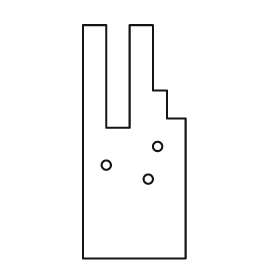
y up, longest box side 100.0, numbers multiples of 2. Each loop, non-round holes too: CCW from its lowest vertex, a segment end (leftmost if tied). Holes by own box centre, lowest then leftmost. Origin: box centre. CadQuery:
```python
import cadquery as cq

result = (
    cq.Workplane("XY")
    .moveTo(-22.0, -50.0)
    .lineTo(22.0, -50.0)
    .lineTo(22.0, 10.0)
    .lineTo(14.0, 10.0)
    .lineTo(14.0, 22.0)
    .lineTo(8.0, 22.0)
    .lineTo(8.0, 50.0)
    .lineTo(-2.0, 50.0)
    .lineTo(-2.0, 6.0)
    .lineTo(-12.0, 6.0)
    .lineTo(-12.0, 50.0)
    .lineTo(-22.0, 50.0)
    .close()
    .moveTo(6.0, -16.0)
    .circle(2.0)
    .moveTo(-12.0, -10.0)
    .circle(2.0)
    .moveTo(10.0, -2.0)
    .circle(2.0)
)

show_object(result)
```